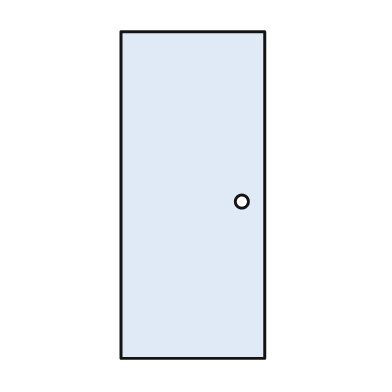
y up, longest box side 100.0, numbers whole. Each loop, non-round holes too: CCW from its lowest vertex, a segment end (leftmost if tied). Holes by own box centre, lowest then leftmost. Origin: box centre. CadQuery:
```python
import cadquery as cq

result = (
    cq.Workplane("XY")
    .moveTo(-22.0, -50.0)
    .lineTo(22.0, -50.0)
    .lineTo(22.0, 50.0)
    .lineTo(-22.0, 50.0)
    .close()
    .moveTo(15.0, -2.0)
    .circle(2.0)
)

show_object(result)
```